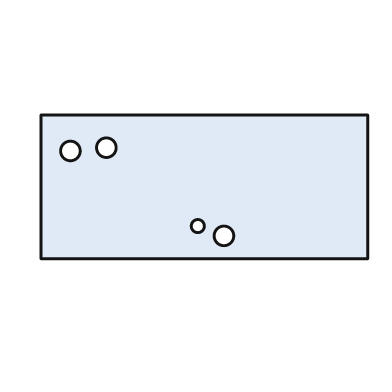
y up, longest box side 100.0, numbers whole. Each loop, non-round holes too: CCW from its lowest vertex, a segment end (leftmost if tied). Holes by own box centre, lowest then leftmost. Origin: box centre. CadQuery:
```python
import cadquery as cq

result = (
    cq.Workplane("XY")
    .moveTo(-50.0, -22.0)
    .lineTo(50.0, -22.0)
    .lineTo(50.0, 22.0)
    .lineTo(-50.0, 22.0)
    .close()
    .moveTo(6.0, -15.0)
    .circle(3.0)
    .moveTo(-2.0, -12.0)
    .circle(2.0)
    .moveTo(-41.0, 11.0)
    .circle(3.0)
    .moveTo(-30.0, 12.0)
    .circle(3.0)
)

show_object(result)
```